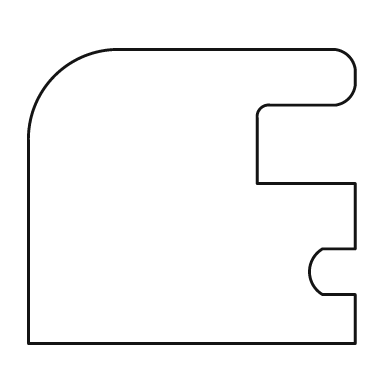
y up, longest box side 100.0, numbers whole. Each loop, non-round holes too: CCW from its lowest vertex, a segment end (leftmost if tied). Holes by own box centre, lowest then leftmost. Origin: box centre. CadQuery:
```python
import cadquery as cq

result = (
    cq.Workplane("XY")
    .moveTo(-50.0, -45.0)
    .lineTo(50.0, -45.0)
    .lineTo(50.0, -30.0)
    .lineTo(40.0, -30.0)
    .threePointArc((36.0, -23.0), (40.0, -16.0))
    .lineTo(50.0, -16.0)
    .lineTo(50.0, 4.0)
    .lineTo(20.0, 4.0)
    .lineTo(20.0, 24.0)
    .threePointArc((21.0, 27.0), (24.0, 28.0))
    .lineTo(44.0, 28.0)
    .threePointArc((48.0, 30.0), (50.0, 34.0))
    .lineTo(50.0, 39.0)
    .threePointArc((48.0, 43.0), (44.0, 45.0))
    .lineTo(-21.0, 45.0)
    .threePointArc((-42.0, 37.0), (-50.0, 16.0))
    .close()
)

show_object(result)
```